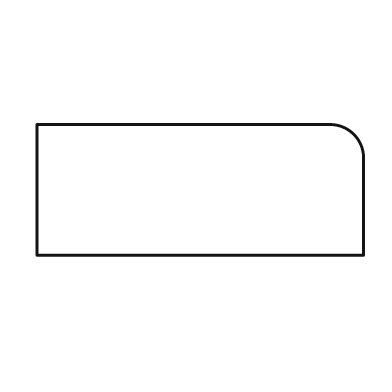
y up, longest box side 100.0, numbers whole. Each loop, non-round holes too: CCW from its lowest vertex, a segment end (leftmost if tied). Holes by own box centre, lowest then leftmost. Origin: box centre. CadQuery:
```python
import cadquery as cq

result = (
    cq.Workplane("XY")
    .moveTo(-50.0, -20.0)
    .lineTo(50.0, -20.0)
    .lineTo(50.0, 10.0)
    .threePointArc((47.0, 17.0), (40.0, 20.0))
    .lineTo(-50.0, 20.0)
    .close()
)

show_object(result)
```